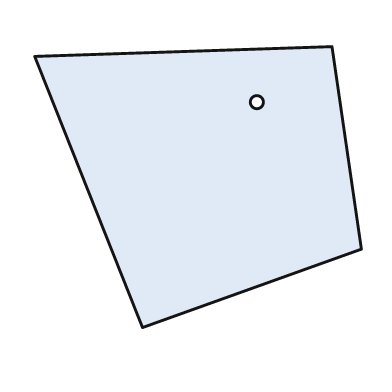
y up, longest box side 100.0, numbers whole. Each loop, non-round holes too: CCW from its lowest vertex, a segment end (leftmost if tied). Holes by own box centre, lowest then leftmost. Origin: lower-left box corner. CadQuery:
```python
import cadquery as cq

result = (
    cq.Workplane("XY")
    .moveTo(33.0, 0.0)
    .lineTo(100.0, 24.0)
    .lineTo(91.0, 86.0)
    .lineTo(0.0, 83.0)
    .close()
    .moveTo(68.0, 69.0)
    .circle(2.0)
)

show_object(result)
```